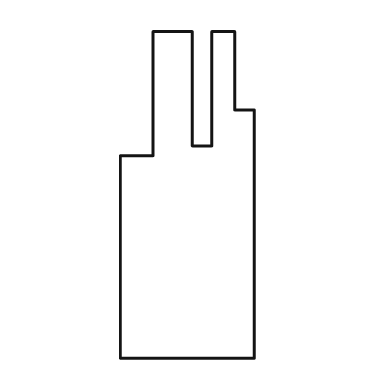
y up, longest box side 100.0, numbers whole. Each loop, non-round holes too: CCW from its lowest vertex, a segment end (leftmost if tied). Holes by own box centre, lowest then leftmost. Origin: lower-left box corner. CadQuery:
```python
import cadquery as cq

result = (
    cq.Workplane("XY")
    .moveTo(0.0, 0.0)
    .lineTo(41.0, 0.0)
    .lineTo(41.0, 76.0)
    .lineTo(35.0, 76.0)
    .lineTo(35.0, 100.0)
    .lineTo(28.0, 100.0)
    .lineTo(28.0, 65.0)
    .lineTo(22.0, 65.0)
    .lineTo(22.0, 100.0)
    .lineTo(10.0, 100.0)
    .lineTo(10.0, 62.0)
    .lineTo(0.0, 62.0)
    .close()
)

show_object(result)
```